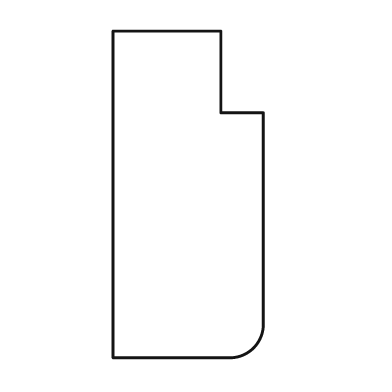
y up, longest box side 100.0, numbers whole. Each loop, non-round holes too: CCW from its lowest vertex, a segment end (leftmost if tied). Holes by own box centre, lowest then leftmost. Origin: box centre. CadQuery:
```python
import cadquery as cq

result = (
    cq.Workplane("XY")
    .moveTo(-23.0, -50.0)
    .lineTo(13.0, -50.0)
    .threePointArc((20.0, -47.0), (23.0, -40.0))
    .lineTo(23.0, 25.0)
    .lineTo(10.0, 25.0)
    .lineTo(10.0, 50.0)
    .lineTo(-23.0, 50.0)
    .close()
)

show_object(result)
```